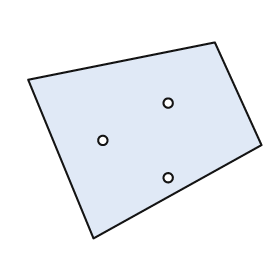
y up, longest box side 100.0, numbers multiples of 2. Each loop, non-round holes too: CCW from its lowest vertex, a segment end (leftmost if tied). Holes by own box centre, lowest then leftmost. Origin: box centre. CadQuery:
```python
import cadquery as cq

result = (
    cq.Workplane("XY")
    .moveTo(-22.0, -42.0)
    .lineTo(50.0, -2.0)
    .lineTo(30.0, 42.0)
    .lineTo(-50.0, 26.0)
    .close()
    .moveTo(10.0, -16.0)
    .circle(2.0)
    .moveTo(-18.0, 0.0)
    .circle(2.0)
    .moveTo(10.0, 16.0)
    .circle(2.0)
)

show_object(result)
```